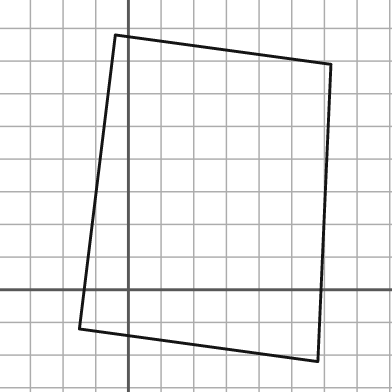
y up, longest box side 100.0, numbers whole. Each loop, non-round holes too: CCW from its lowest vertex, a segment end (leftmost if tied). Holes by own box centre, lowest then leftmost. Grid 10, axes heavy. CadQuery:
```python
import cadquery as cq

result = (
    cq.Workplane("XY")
    .moveTo(58.0, -22.0)
    .lineTo(62.0, 69.0)
    .lineTo(-4.0, 78.0)
    .lineTo(-15.0, -12.0)
    .close()
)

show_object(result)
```